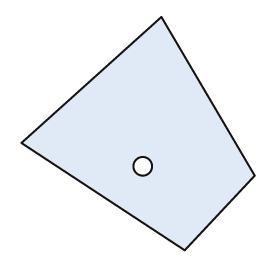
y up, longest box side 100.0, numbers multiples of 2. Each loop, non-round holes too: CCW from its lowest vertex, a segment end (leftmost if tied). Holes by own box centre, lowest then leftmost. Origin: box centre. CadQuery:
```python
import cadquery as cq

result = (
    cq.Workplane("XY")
    .moveTo(20.0, -50.0)
    .lineTo(50.0, -18.0)
    .lineTo(10.0, 50.0)
    .lineTo(-50.0, -4.0)
    .close()
    .moveTo(2.0, -14.0)
    .circle(4.0)
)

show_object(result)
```